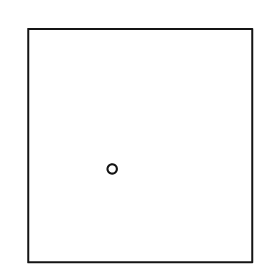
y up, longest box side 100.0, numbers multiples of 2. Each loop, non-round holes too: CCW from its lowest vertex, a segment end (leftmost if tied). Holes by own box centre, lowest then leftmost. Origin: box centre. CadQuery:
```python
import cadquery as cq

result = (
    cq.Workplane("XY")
    .moveTo(-48.0, -50.0)
    .lineTo(48.0, -50.0)
    .lineTo(48.0, 50.0)
    .lineTo(-48.0, 50.0)
    .close()
    .moveTo(-12.0, -10.0)
    .circle(2.0)
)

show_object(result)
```